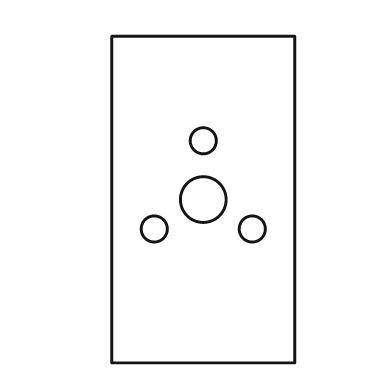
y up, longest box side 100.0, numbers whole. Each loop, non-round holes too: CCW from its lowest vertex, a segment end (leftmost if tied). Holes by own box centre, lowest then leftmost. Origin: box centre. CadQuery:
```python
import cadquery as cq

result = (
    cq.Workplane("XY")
    .moveTo(-28.0, -50.0)
    .lineTo(28.0, -50.0)
    .lineTo(28.0, 50.0)
    .lineTo(-28.0, 50.0)
    .close()
    .moveTo(-15.0, -9.0)
    .circle(4.0)
    .moveTo(15.0, -9.0)
    .circle(4.0)
    .moveTo(0.0, 0.0)
    .circle(7.0)
    .moveTo(0.0, 18.0)
    .circle(4.0)
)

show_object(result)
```